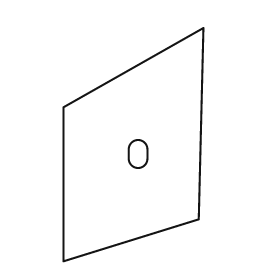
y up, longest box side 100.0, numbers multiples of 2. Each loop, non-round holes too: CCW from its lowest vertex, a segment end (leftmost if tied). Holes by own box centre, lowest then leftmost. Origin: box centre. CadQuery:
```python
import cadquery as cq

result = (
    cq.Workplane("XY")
    .moveTo(-30.0, -50.0)
    .lineTo(28.0, -32.0)
    .lineTo(30.0, 50.0)
    .lineTo(-30.0, 16.0)
    .close()
    .moveTo(-2.0, -6.0)
    .threePointArc((2.0, -10.0), (6.0, -6.0))
    .lineTo(6.0, -2.0)
    .threePointArc((2.0, 2.0), (-2.0, -2.0))
    .close()
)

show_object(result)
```